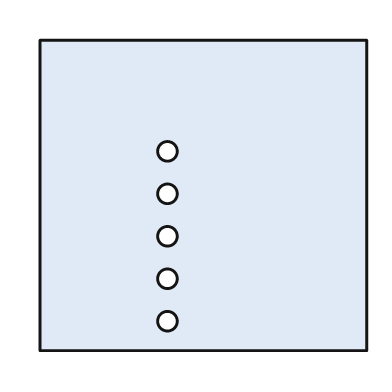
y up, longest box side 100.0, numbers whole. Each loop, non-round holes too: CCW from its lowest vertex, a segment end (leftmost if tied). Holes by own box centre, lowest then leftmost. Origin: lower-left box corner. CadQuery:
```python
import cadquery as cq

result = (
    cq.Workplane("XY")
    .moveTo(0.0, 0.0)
    .lineTo(100.0, 0.0)
    .lineTo(100.0, 95.0)
    .lineTo(0.0, 95.0)
    .close()
    .moveTo(39.0, 9.0)
    .circle(3.0)
    .moveTo(39.0, 22.0)
    .circle(3.0)
    .moveTo(39.0, 35.0)
    .circle(3.0)
    .moveTo(39.0, 48.0)
    .circle(3.0)
    .moveTo(39.0, 61.0)
    .circle(3.0)
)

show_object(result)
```